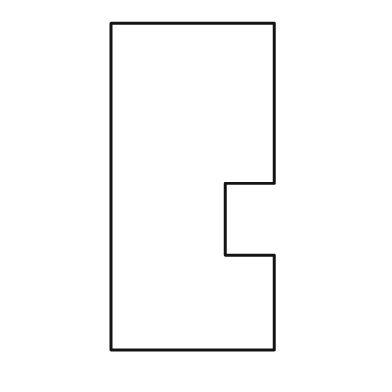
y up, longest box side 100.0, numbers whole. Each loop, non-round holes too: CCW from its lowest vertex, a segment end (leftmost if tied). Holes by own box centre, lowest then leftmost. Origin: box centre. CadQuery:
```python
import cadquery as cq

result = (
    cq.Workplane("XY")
    .moveTo(-25.0, -50.0)
    .lineTo(25.0, -50.0)
    .lineTo(25.0, -21.0)
    .lineTo(10.0, -21.0)
    .lineTo(10.0, 1.0)
    .lineTo(25.0, 1.0)
    .lineTo(25.0, 50.0)
    .lineTo(-25.0, 50.0)
    .close()
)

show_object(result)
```